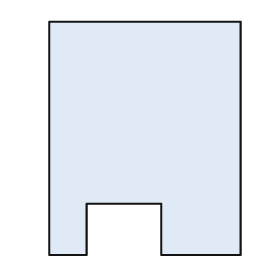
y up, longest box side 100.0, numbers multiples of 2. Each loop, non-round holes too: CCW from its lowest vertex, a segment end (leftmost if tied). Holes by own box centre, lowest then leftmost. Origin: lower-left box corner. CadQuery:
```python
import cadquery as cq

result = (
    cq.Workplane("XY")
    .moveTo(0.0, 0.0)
    .lineTo(16.0, 0.0)
    .lineTo(16.0, 22.0)
    .lineTo(48.0, 22.0)
    .lineTo(48.0, 0.0)
    .lineTo(82.0, 0.0)
    .lineTo(82.0, 100.0)
    .lineTo(0.0, 100.0)
    .close()
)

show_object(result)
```